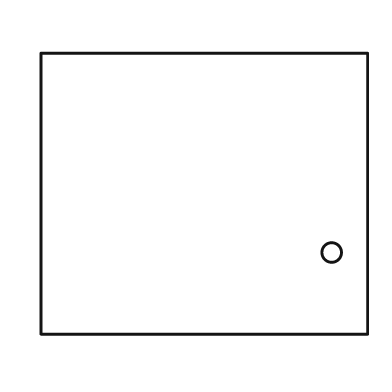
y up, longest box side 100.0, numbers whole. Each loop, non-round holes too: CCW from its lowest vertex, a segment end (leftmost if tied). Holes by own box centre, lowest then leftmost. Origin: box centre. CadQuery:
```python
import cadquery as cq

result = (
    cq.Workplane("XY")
    .moveTo(-50.0, -43.0)
    .lineTo(50.0, -43.0)
    .lineTo(50.0, 43.0)
    .lineTo(-50.0, 43.0)
    .close()
    .moveTo(39.0, -18.0)
    .circle(3.0)
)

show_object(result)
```